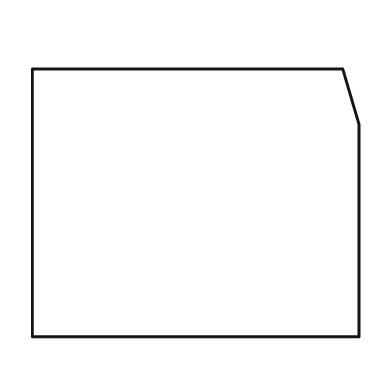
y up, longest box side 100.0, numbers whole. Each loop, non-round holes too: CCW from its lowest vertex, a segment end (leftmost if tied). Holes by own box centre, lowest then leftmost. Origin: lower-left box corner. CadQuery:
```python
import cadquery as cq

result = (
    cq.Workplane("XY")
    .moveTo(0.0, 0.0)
    .lineTo(100.0, 0.0)
    .lineTo(100.0, 65.0)
    .lineTo(95.0, 82.0)
    .lineTo(0.0, 82.0)
    .close()
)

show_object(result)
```